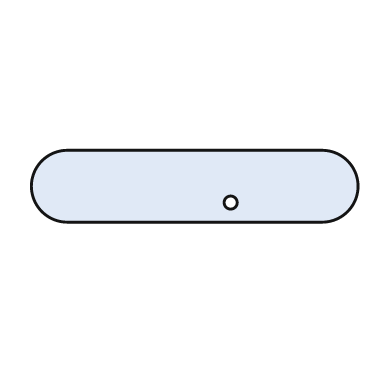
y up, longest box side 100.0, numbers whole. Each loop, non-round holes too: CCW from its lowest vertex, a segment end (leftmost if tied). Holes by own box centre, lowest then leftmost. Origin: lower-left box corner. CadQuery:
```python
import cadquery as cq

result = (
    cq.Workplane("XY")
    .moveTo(11.0, 0.0)
    .lineTo(89.0, 0.0)
    .threePointArc((100.0, 11.0), (89.0, 22.0))
    .lineTo(11.0, 22.0)
    .threePointArc((0.0, 11.0), (11.0, 0.0))
    .close()
    .moveTo(61.0, 6.0)
    .circle(2.0)
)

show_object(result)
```